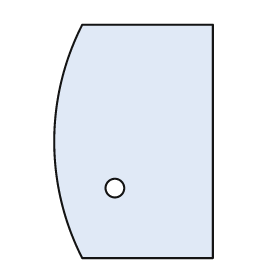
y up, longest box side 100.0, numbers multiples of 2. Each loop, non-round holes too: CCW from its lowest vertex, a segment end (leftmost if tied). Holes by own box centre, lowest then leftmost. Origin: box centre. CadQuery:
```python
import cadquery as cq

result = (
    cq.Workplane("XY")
    .moveTo(-22.0, -50.0)
    .lineTo(34.0, -50.0)
    .lineTo(34.0, 50.0)
    .lineTo(-22.0, 50.0)
    .threePointArc((-34.0, 0.0), (-22.0, -50.0))
    .close()
    .moveTo(-8.0, -20.0)
    .circle(4.0)
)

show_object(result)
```